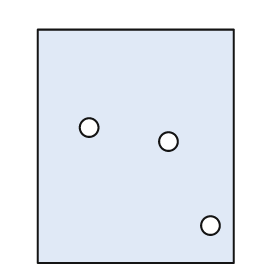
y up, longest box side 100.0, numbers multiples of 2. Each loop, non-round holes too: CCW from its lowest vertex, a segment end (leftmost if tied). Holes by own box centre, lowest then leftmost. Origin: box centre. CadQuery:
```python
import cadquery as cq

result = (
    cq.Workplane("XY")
    .moveTo(-42.0, -50.0)
    .lineTo(42.0, -50.0)
    .lineTo(42.0, 50.0)
    .lineTo(-42.0, 50.0)
    .close()
    .moveTo(32.0, -34.0)
    .circle(4.0)
    .moveTo(14.0, 2.0)
    .circle(4.0)
    .moveTo(-20.0, 8.0)
    .circle(4.0)
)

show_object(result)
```